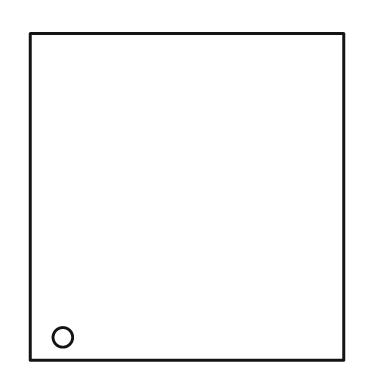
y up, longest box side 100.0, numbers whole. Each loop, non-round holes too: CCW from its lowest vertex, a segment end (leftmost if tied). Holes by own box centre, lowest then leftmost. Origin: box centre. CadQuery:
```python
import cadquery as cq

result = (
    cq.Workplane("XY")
    .moveTo(-48.0, -50.0)
    .lineTo(48.0, -50.0)
    .lineTo(48.0, 50.0)
    .lineTo(-48.0, 50.0)
    .close()
    .moveTo(-38.0, -43.0)
    .circle(3.0)
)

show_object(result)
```